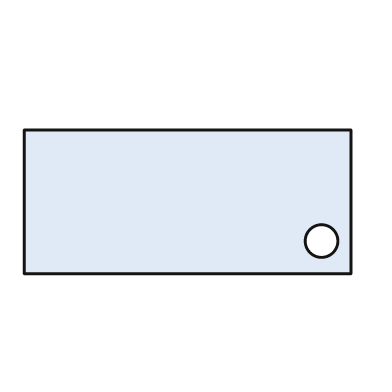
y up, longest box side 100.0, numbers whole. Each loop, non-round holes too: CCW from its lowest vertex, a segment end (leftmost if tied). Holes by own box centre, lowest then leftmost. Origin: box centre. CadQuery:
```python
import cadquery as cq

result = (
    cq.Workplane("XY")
    .moveTo(-50.0, -22.0)
    .lineTo(50.0, -22.0)
    .lineTo(50.0, 22.0)
    .lineTo(-50.0, 22.0)
    .close()
    .moveTo(41.0, -12.0)
    .circle(5.0)
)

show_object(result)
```